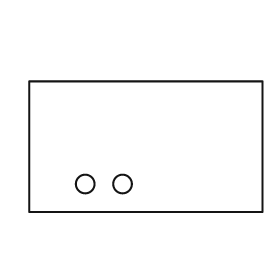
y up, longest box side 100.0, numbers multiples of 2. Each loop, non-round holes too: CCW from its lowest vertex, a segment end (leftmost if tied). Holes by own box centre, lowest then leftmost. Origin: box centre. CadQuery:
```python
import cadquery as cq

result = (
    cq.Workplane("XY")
    .moveTo(-50.0, -28.0)
    .lineTo(50.0, -28.0)
    .lineTo(50.0, 28.0)
    .lineTo(-50.0, 28.0)
    .close()
    .moveTo(-26.0, -16.0)
    .circle(4.0)
    .moveTo(-10.0, -16.0)
    .circle(4.0)
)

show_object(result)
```